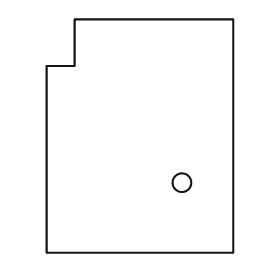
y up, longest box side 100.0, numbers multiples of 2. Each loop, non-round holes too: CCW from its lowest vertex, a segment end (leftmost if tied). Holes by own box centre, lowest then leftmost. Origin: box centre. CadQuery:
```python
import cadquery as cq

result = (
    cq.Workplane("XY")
    .moveTo(-40.0, -50.0)
    .lineTo(40.0, -50.0)
    .lineTo(40.0, 50.0)
    .lineTo(-28.0, 50.0)
    .lineTo(-28.0, 30.0)
    .lineTo(-40.0, 30.0)
    .close()
    .moveTo(18.0, -20.0)
    .circle(4.0)
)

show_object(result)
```